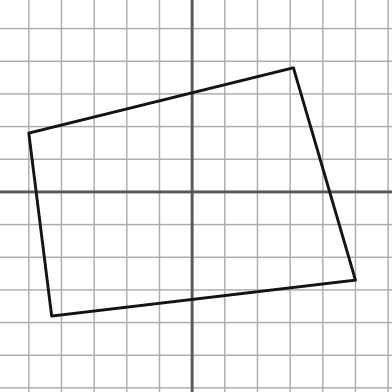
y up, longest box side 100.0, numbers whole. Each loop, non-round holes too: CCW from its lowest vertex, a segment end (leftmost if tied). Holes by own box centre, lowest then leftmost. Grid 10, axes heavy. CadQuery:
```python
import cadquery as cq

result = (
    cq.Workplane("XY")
    .moveTo(-43.0, -38.0)
    .lineTo(50.0, -27.0)
    .lineTo(31.0, 38.0)
    .lineTo(-50.0, 18.0)
    .close()
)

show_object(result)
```